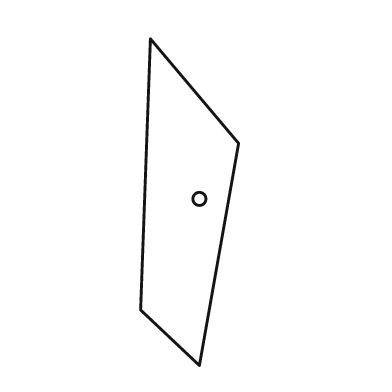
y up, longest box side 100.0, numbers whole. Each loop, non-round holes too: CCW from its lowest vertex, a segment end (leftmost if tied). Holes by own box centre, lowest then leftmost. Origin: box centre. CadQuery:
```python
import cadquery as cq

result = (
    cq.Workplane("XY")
    .moveTo(3.0, -50.0)
    .lineTo(15.0, 18.0)
    .lineTo(-12.0, 50.0)
    .lineTo(-15.0, -33.0)
    .close()
    .moveTo(3.0, 1.0)
    .circle(2.0)
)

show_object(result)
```